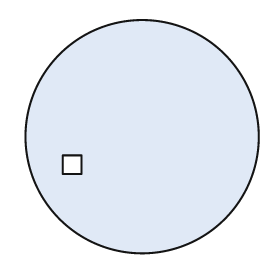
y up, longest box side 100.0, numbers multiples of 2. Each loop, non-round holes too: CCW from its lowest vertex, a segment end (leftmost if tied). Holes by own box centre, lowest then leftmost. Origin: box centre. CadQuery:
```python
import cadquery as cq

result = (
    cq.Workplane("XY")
    .moveTo(0.0, 0.0)
    .circle(50.0)
    .moveTo(-34.0, -16.0)
    .lineTo(-26.0, -16.0)
    .lineTo(-26.0, -8.0)
    .lineTo(-34.0, -8.0)
    .close()
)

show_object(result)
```